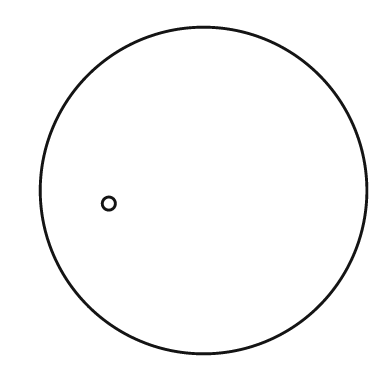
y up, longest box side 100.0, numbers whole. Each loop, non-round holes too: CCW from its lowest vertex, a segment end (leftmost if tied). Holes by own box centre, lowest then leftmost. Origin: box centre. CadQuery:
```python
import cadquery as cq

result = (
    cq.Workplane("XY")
    .moveTo(0.0, 0.0)
    .circle(50.0)
    .moveTo(-29.0, -4.0)
    .circle(2.0)
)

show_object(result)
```